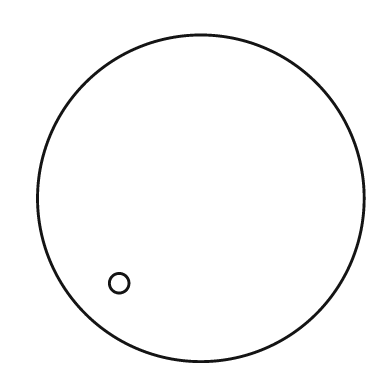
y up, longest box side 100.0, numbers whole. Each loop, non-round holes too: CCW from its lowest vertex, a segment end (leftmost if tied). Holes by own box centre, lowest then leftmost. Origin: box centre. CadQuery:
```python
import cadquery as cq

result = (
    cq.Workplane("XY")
    .moveTo(0.0, 0.0)
    .circle(50.0)
    .moveTo(-25.0, -26.0)
    .circle(3.0)
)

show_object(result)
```